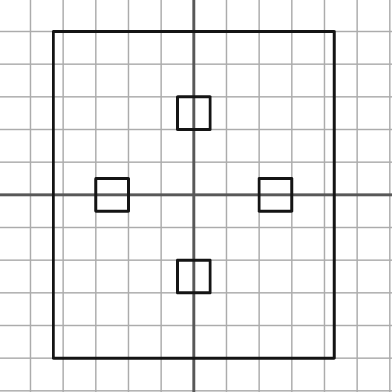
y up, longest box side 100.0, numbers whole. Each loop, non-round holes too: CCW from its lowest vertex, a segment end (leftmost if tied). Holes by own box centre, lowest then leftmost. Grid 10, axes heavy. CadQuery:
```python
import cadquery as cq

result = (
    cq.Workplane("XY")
    .moveTo(-43.0, -50.0)
    .lineTo(43.0, -50.0)
    .lineTo(43.0, 50.0)
    .lineTo(-43.0, 50.0)
    .close()
    .moveTo(-5.0, -30.0)
    .lineTo(5.0, -30.0)
    .lineTo(5.0, -20.0)
    .lineTo(-5.0, -20.0)
    .close()
    .moveTo(-30.0, -5.0)
    .lineTo(-20.0, -5.0)
    .lineTo(-20.0, 5.0)
    .lineTo(-30.0, 5.0)
    .close()
    .moveTo(20.0, -5.0)
    .lineTo(30.0, -5.0)
    .lineTo(30.0, 5.0)
    .lineTo(20.0, 5.0)
    .close()
    .moveTo(-5.0, 20.0)
    .lineTo(5.0, 20.0)
    .lineTo(5.0, 30.0)
    .lineTo(-5.0, 30.0)
    .close()
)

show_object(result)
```